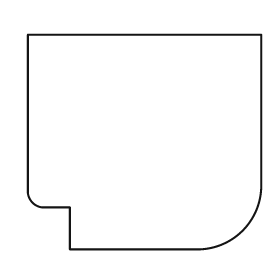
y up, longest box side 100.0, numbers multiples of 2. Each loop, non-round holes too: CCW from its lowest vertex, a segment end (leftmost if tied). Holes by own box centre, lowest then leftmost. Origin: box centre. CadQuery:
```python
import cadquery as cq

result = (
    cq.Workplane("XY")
    .moveTo(-32.0, -46.0)
    .lineTo(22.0, -46.0)
    .threePointArc((42.0, -38.0), (50.0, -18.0))
    .lineTo(50.0, 46.0)
    .lineTo(-50.0, 46.0)
    .lineTo(-50.0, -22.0)
    .threePointArc((-48.0, -26.0), (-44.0, -28.0))
    .lineTo(-32.0, -28.0)
    .close()
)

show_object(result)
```